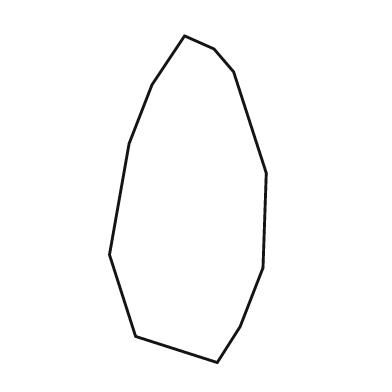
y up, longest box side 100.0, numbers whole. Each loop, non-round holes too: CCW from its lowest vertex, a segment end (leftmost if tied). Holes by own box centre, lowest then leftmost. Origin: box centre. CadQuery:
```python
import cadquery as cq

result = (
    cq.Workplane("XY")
    .moveTo(9.0, -50.0)
    .lineTo(16.0, -39.0)
    .lineTo(23.0, -21.0)
    .lineTo(24.0, 8.0)
    .lineTo(14.0, 39.0)
    .lineTo(8.0, 46.0)
    .lineTo(-1.0, 50.0)
    .lineTo(-11.0, 35.0)
    .lineTo(-18.0, 17.0)
    .lineTo(-24.0, -17.0)
    .lineTo(-16.0, -42.0)
    .close()
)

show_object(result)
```